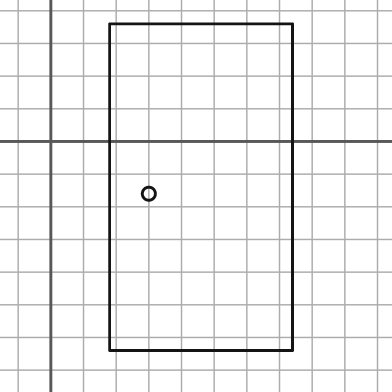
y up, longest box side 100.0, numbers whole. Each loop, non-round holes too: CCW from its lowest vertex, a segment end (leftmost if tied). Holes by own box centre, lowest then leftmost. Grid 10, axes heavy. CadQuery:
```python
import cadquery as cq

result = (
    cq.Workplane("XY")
    .moveTo(18.0, -64.0)
    .lineTo(74.0, -64.0)
    .lineTo(74.0, 36.0)
    .lineTo(18.0, 36.0)
    .close()
    .moveTo(30.0, -16.0)
    .circle(2.0)
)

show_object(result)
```